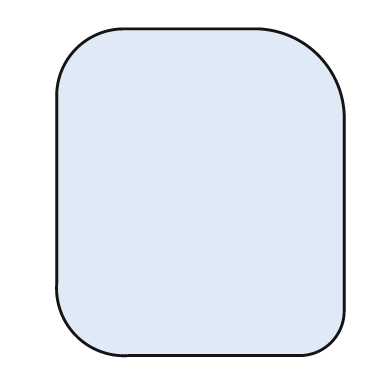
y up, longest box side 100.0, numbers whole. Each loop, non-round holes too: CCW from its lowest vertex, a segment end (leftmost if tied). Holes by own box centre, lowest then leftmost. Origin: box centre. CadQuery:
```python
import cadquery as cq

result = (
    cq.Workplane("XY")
    .moveTo(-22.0, -50.0)
    .lineTo(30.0, -50.0)
    .threePointArc((40.0, -46.0), (44.0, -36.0))
    .lineTo(44.0, 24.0)
    .threePointArc((36.0, 42.0), (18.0, 50.0))
    .lineTo(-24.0, 50.0)
    .threePointArc((-38.0, 44.0), (-44.0, 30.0))
    .lineTo(-44.0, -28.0)
    .threePointArc((-38.0, -44.0), (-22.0, -50.0))
    .close()
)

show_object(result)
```